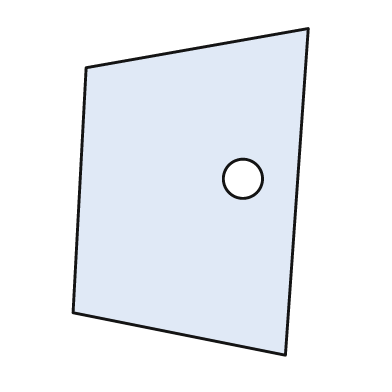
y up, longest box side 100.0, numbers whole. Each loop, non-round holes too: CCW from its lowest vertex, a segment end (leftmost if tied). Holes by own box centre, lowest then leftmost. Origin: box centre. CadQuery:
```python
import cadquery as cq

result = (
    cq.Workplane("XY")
    .moveTo(29.0, -50.0)
    .lineTo(36.0, 50.0)
    .lineTo(-32.0, 38.0)
    .lineTo(-36.0, -37.0)
    .close()
    .moveTo(16.0, 4.0)
    .circle(6.0)
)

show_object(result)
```